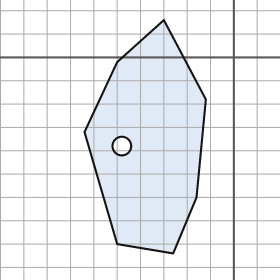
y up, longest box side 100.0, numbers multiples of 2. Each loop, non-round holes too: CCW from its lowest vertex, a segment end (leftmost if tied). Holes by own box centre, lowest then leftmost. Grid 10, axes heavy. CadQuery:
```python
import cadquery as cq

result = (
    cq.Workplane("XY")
    .moveTo(-26.0, -84.0)
    .lineTo(-16.0, -60.0)
    .lineTo(-12.0, -18.0)
    .lineTo(-30.0, 16.0)
    .lineTo(-50.0, -2.0)
    .lineTo(-64.0, -32.0)
    .lineTo(-50.0, -80.0)
    .close()
    .moveTo(-48.0, -38.0)
    .circle(4.0)
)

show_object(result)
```